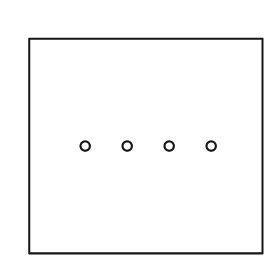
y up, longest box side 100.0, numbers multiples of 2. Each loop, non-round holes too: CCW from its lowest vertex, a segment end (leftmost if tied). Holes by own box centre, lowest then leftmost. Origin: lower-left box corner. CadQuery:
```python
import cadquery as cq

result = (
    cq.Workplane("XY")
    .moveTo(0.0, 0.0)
    .lineTo(100.0, 0.0)
    .lineTo(100.0, 92.0)
    .lineTo(0.0, 92.0)
    .close()
    .moveTo(24.0, 46.0)
    .circle(2.0)
    .moveTo(42.0, 46.0)
    .circle(2.0)
    .moveTo(60.0, 46.0)
    .circle(2.0)
    .moveTo(78.0, 46.0)
    .circle(2.0)
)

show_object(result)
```